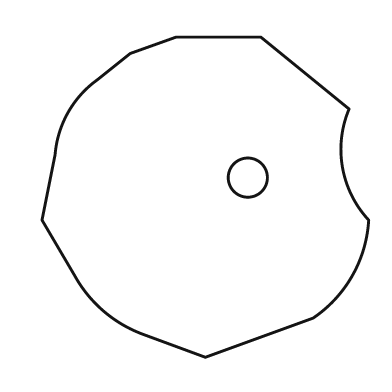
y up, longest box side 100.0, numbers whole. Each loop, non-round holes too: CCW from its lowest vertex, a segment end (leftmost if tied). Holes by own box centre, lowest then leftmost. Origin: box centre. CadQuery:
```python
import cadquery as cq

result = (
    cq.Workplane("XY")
    .moveTo(0.0, -49.0)
    .lineTo(33.0, -37.0)
    .threePointArc((45.0, -24.0), (50.0, -7.0))
    .threePointArc((42.0, 9.0), (44.0, 27.0))
    .lineTo(17.0, 49.0)
    .lineTo(-9.0, 49.0)
    .lineTo(-23.0, 44.0)
    .lineTo(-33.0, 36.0)
    .threePointArc((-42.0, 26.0), (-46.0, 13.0))
    .lineTo(-50.0, -7.0)
    .lineTo(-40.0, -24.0)
    .threePointArc((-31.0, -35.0), (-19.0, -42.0))
    .close()
    .moveTo(13.0, 6.0)
    .circle(6.0)
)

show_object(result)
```